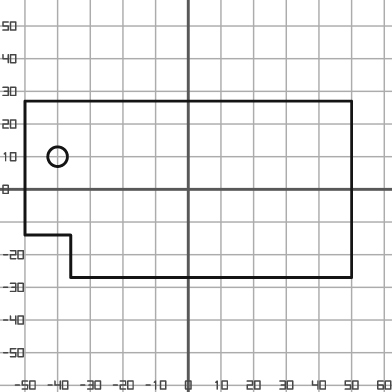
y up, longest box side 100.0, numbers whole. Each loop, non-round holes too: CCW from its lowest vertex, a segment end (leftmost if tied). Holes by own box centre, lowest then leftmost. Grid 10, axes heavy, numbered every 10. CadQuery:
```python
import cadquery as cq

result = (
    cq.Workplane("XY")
    .moveTo(-36.0, -27.0)
    .lineTo(50.0, -27.0)
    .lineTo(50.0, 27.0)
    .lineTo(-50.0, 27.0)
    .lineTo(-50.0, -14.0)
    .lineTo(-36.0, -14.0)
    .close()
    .moveTo(-40.0, 10.0)
    .circle(3.0)
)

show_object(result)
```